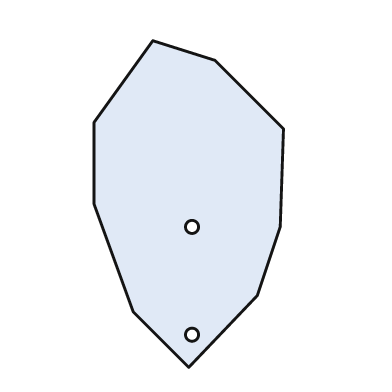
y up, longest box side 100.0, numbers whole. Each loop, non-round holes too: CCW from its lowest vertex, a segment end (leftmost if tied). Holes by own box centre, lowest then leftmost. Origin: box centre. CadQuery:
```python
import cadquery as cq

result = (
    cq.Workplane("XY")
    .moveTo(0.0, -50.0)
    .lineTo(21.0, -28.0)
    .lineTo(28.0, -7.0)
    .lineTo(29.0, 23.0)
    .lineTo(8.0, 44.0)
    .lineTo(-11.0, 50.0)
    .lineTo(-29.0, 25.0)
    .lineTo(-29.0, 0.0)
    .lineTo(-17.0, -33.0)
    .close()
    .moveTo(1.0, -40.0)
    .circle(2.0)
    .moveTo(1.0, -7.0)
    .circle(2.0)
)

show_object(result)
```